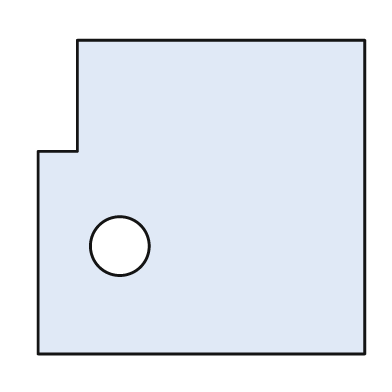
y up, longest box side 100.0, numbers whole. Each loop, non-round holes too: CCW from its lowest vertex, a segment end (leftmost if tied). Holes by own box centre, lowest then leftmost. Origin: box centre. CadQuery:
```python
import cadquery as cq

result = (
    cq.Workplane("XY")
    .moveTo(-50.0, -48.0)
    .lineTo(50.0, -48.0)
    .lineTo(50.0, 48.0)
    .lineTo(-38.0, 48.0)
    .lineTo(-38.0, 14.0)
    .lineTo(-50.0, 14.0)
    .close()
    .moveTo(-25.0, -15.0)
    .circle(9.0)
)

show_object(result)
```